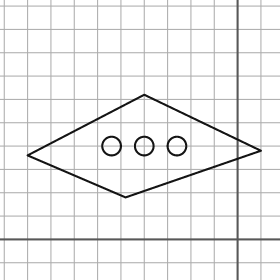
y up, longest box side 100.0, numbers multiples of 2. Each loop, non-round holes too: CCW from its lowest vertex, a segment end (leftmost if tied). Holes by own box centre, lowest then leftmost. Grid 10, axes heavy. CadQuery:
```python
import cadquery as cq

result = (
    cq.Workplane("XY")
    .moveTo(-48.0, 18.0)
    .lineTo(10.0, 38.0)
    .lineTo(-40.0, 62.0)
    .lineTo(-90.0, 36.0)
    .close()
    .moveTo(-54.0, 40.0)
    .circle(4.0)
    .moveTo(-40.0, 40.0)
    .circle(4.0)
    .moveTo(-26.0, 40.0)
    .circle(4.0)
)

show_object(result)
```